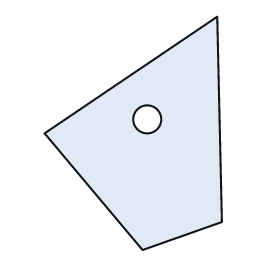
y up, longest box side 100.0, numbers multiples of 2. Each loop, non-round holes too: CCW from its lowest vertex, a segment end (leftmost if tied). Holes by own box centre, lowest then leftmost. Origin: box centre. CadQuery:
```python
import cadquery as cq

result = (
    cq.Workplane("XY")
    .moveTo(4.0, -50.0)
    .lineTo(38.0, -38.0)
    .lineTo(36.0, 50.0)
    .lineTo(-38.0, 0.0)
    .close()
    .moveTo(6.0, 6.0)
    .circle(6.0)
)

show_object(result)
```